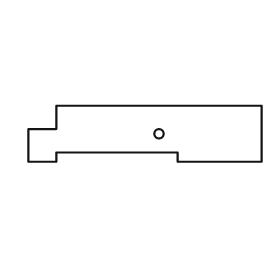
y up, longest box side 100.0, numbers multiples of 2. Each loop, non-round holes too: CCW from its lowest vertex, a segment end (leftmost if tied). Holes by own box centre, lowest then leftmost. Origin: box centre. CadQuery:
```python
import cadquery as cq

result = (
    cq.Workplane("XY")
    .moveTo(-50.0, -12.0)
    .lineTo(-38.0, -12.0)
    .lineTo(-38.0, -8.0)
    .lineTo(14.0, -8.0)
    .lineTo(14.0, -12.0)
    .lineTo(50.0, -12.0)
    .lineTo(50.0, 12.0)
    .lineTo(-38.0, 12.0)
    .lineTo(-38.0, 2.0)
    .lineTo(-50.0, 2.0)
    .close()
    .moveTo(6.0, 0.0)
    .circle(2.0)
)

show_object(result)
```